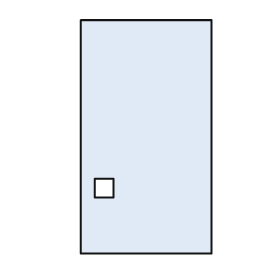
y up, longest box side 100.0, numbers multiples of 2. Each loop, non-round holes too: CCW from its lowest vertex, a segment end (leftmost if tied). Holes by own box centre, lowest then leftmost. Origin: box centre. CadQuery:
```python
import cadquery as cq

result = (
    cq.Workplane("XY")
    .moveTo(-28.0, -50.0)
    .lineTo(28.0, -50.0)
    .lineTo(28.0, 50.0)
    .lineTo(-28.0, 50.0)
    .close()
    .moveTo(-22.0, -26.0)
    .lineTo(-14.0, -26.0)
    .lineTo(-14.0, -18.0)
    .lineTo(-22.0, -18.0)
    .close()
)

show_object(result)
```